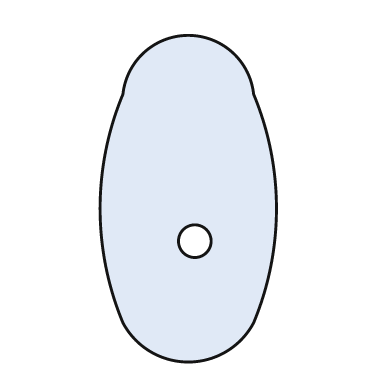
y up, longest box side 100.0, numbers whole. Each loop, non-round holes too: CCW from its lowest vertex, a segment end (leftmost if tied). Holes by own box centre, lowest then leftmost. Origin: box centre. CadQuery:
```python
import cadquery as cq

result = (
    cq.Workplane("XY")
    .moveTo(-20.0, -38.0)
    .threePointArc((0.0, -50.0), (20.0, -38.0))
    .threePointArc((27.0, -3.0), (20.0, 32.0))
    .threePointArc((0.0, 50.0), (-20.0, 32.0))
    .threePointArc((-27.0, -3.0), (-20.0, -38.0))
    .close()
    .moveTo(2.0, -13.0)
    .circle(5.0)
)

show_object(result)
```